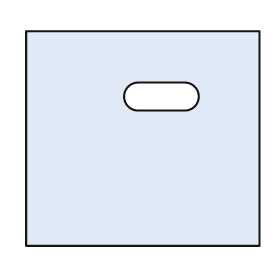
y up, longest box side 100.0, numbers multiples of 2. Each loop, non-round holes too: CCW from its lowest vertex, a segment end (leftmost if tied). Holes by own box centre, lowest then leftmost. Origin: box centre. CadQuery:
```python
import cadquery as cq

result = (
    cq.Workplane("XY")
    .moveTo(-50.0, -46.0)
    .lineTo(50.0, -46.0)
    .lineTo(50.0, 46.0)
    .lineTo(-50.0, 46.0)
    .close()
    .moveTo(-2.0, 12.0)
    .lineTo(18.0, 12.0)
    .threePointArc((24.0, 18.0), (18.0, 24.0))
    .lineTo(-2.0, 24.0)
    .threePointArc((-8.0, 18.0), (-2.0, 12.0))
    .close()
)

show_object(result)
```